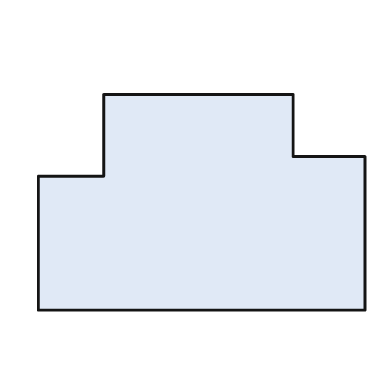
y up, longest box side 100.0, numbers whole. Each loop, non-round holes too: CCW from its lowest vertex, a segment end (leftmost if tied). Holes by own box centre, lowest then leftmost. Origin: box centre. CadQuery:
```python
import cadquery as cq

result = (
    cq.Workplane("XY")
    .moveTo(-50.0, -33.0)
    .lineTo(50.0, -33.0)
    .lineTo(50.0, 14.0)
    .lineTo(28.0, 14.0)
    .lineTo(28.0, 33.0)
    .lineTo(-30.0, 33.0)
    .lineTo(-30.0, 8.0)
    .lineTo(-50.0, 8.0)
    .close()
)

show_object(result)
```